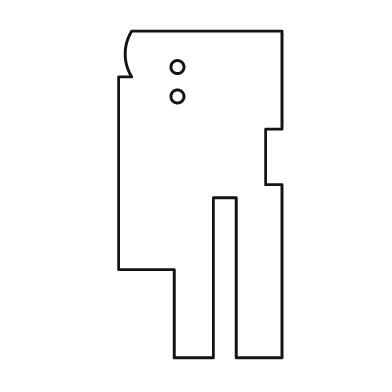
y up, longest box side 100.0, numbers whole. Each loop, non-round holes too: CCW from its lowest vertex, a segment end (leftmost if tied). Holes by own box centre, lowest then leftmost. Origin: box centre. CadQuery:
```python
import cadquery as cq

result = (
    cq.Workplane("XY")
    .moveTo(-8.0, -50.0)
    .lineTo(4.0, -50.0)
    .lineTo(4.0, -1.0)
    .lineTo(11.0, -1.0)
    .lineTo(11.0, -50.0)
    .lineTo(25.0, -50.0)
    .lineTo(25.0, 3.0)
    .lineTo(20.0, 3.0)
    .lineTo(20.0, 20.0)
    .lineTo(25.0, 20.0)
    .lineTo(25.0, 50.0)
    .lineTo(-21.0, 50.0)
    .threePointArc((-23.0, 43.0), (-21.0, 36.0))
    .lineTo(-25.0, 36.0)
    .lineTo(-25.0, -23.0)
    .lineTo(-8.0, -23.0)
    .close()
    .moveTo(-7.0, 30.0)
    .circle(2.0)
    .moveTo(-7.0, 39.0)
    .circle(2.0)
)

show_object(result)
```